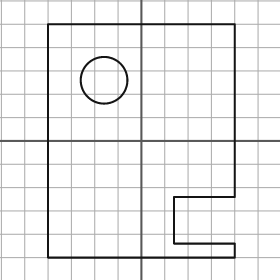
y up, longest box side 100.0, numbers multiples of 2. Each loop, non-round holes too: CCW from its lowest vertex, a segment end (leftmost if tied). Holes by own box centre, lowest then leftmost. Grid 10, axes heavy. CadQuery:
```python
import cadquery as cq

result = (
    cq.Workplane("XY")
    .moveTo(-40.0, -50.0)
    .lineTo(40.0, -50.0)
    .lineTo(40.0, -44.0)
    .lineTo(14.0, -44.0)
    .lineTo(14.0, -24.0)
    .lineTo(40.0, -24.0)
    .lineTo(40.0, 50.0)
    .lineTo(-40.0, 50.0)
    .close()
    .moveTo(-16.0, 26.0)
    .circle(10.0)
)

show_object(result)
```